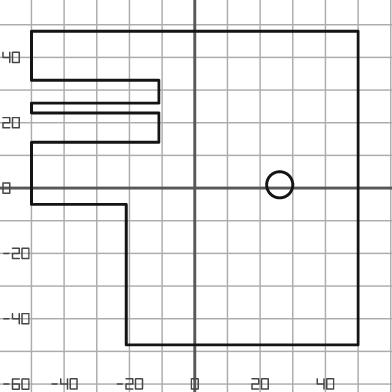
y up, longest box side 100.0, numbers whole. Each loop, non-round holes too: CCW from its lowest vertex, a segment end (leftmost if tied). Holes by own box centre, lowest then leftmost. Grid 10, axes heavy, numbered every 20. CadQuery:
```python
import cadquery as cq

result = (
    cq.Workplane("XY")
    .moveTo(-21.0, -48.0)
    .lineTo(50.0, -48.0)
    .lineTo(50.0, 48.0)
    .lineTo(-50.0, 48.0)
    .lineTo(-50.0, 33.0)
    .lineTo(-11.0, 33.0)
    .lineTo(-11.0, 26.0)
    .lineTo(-50.0, 26.0)
    .lineTo(-50.0, 23.0)
    .lineTo(-11.0, 23.0)
    .lineTo(-11.0, 14.0)
    .lineTo(-50.0, 14.0)
    .lineTo(-50.0, -5.0)
    .lineTo(-21.0, -5.0)
    .close()
    .moveTo(26.0, 1.0)
    .circle(4.0)
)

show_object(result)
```